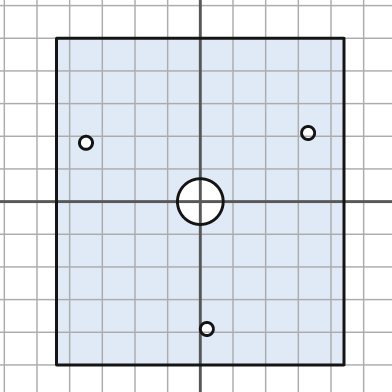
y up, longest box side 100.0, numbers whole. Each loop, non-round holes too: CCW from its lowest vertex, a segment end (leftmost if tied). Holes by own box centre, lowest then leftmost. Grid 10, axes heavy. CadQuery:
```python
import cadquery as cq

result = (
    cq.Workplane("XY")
    .moveTo(-44.0, -50.0)
    .lineTo(44.0, -50.0)
    .lineTo(44.0, 50.0)
    .lineTo(-44.0, 50.0)
    .close()
    .moveTo(2.0, -39.0)
    .circle(2.0)
    .moveTo(0.0, 0.0)
    .circle(7.0)
    .moveTo(-35.0, 18.0)
    .circle(2.0)
    .moveTo(33.0, 21.0)
    .circle(2.0)
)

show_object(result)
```